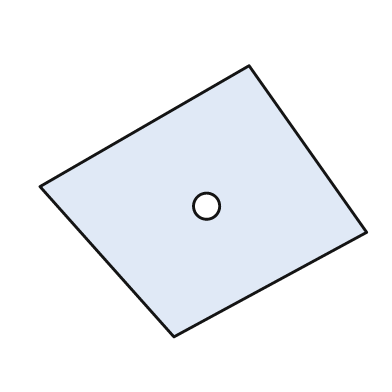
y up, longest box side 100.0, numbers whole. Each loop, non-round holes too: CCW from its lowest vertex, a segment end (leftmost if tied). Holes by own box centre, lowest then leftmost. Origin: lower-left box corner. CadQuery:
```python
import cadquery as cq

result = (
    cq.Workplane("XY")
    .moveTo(41.0, 0.0)
    .lineTo(100.0, 32.0)
    .lineTo(64.0, 83.0)
    .lineTo(0.0, 46.0)
    .close()
    .moveTo(51.0, 40.0)
    .circle(4.0)
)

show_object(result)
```